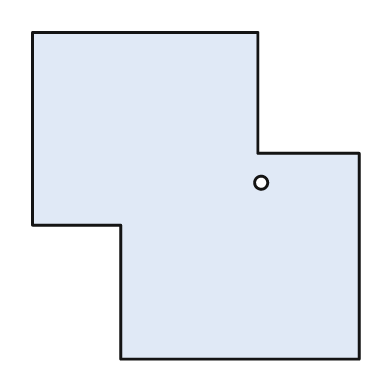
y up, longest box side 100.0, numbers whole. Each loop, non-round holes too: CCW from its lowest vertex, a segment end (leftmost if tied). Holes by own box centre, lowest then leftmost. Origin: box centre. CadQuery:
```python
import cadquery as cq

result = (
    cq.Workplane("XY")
    .moveTo(-23.0, -50.0)
    .lineTo(50.0, -50.0)
    .lineTo(50.0, 13.0)
    .lineTo(19.0, 13.0)
    .lineTo(19.0, 50.0)
    .lineTo(-50.0, 50.0)
    .lineTo(-50.0, -9.0)
    .lineTo(-23.0, -9.0)
    .close()
    .moveTo(20.0, 4.0)
    .circle(2.0)
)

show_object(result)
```